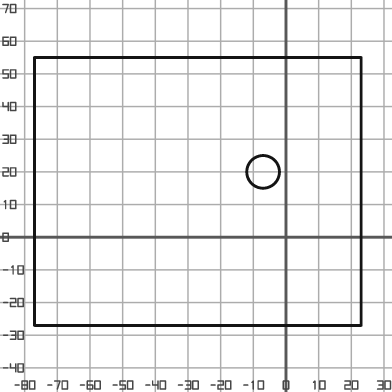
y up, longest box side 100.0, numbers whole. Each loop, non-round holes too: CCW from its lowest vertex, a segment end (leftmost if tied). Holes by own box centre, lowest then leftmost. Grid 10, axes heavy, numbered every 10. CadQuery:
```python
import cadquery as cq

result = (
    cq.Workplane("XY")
    .moveTo(-77.0, -27.0)
    .lineTo(23.0, -27.0)
    .lineTo(23.0, 55.0)
    .lineTo(-77.0, 55.0)
    .close()
    .moveTo(-7.0, 20.0)
    .circle(5.0)
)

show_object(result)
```